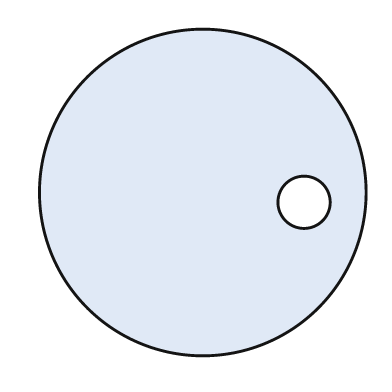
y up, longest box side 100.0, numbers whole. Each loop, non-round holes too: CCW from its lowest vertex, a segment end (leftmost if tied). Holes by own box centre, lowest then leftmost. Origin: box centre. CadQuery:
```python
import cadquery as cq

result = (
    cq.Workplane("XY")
    .moveTo(0.0, 0.0)
    .circle(50.0)
    .moveTo(31.0, -3.0)
    .circle(8.0)
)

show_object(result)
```